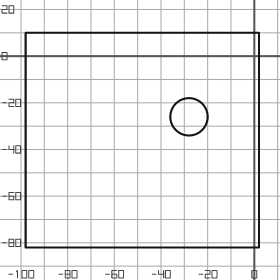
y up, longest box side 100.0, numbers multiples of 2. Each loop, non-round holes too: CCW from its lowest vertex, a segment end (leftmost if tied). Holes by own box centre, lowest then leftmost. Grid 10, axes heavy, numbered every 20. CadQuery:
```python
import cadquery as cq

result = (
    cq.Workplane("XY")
    .moveTo(-98.0, -82.0)
    .lineTo(2.0, -82.0)
    .lineTo(2.0, 10.0)
    .lineTo(-98.0, 10.0)
    .close()
    .moveTo(-28.0, -26.0)
    .circle(8.0)
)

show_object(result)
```